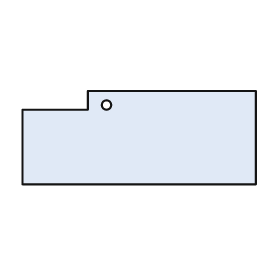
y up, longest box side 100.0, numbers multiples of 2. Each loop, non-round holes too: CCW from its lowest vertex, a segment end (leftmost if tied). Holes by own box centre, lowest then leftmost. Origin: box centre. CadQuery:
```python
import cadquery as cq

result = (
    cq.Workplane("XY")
    .moveTo(-50.0, -20.0)
    .lineTo(50.0, -20.0)
    .lineTo(50.0, 20.0)
    .lineTo(-22.0, 20.0)
    .lineTo(-22.0, 12.0)
    .lineTo(-50.0, 12.0)
    .close()
    .moveTo(-14.0, 14.0)
    .circle(2.0)
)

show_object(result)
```